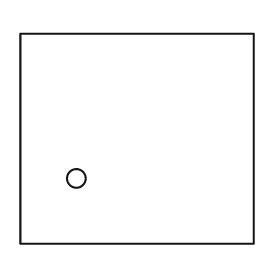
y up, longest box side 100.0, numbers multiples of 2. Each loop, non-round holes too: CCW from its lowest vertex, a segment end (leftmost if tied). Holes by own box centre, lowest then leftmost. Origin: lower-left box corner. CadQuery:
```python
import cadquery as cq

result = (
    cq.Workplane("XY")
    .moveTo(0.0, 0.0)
    .lineTo(100.0, 0.0)
    .lineTo(100.0, 90.0)
    .lineTo(0.0, 90.0)
    .close()
    .moveTo(24.0, 28.0)
    .circle(4.0)
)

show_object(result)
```